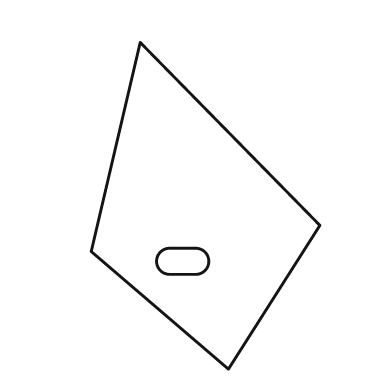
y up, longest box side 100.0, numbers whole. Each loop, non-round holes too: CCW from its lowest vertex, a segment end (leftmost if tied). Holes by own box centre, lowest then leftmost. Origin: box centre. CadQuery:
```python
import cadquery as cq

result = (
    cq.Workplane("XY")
    .moveTo(7.0, -50.0)
    .lineTo(35.0, -6.0)
    .lineTo(-20.0, 50.0)
    .lineTo(-35.0, -14.0)
    .close()
    .moveTo(-11.0, -21.0)
    .lineTo(-3.0, -21.0)
    .threePointArc((1.0, -17.0), (-3.0, -13.0))
    .lineTo(-11.0, -13.0)
    .threePointArc((-15.0, -17.0), (-11.0, -21.0))
    .close()
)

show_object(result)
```